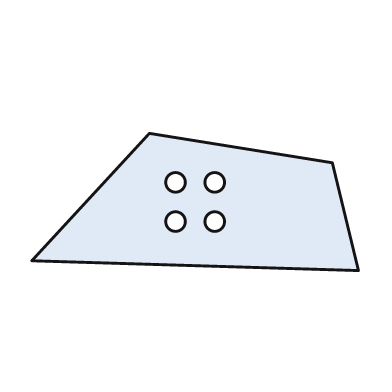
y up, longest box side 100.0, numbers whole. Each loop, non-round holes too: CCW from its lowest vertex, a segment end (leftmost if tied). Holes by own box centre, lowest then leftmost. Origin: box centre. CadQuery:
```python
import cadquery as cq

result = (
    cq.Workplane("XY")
    .moveTo(50.0, -21.0)
    .lineTo(42.0, 12.0)
    .lineTo(-14.0, 21.0)
    .lineTo(-50.0, -18.0)
    .close()
    .moveTo(-6.0, -6.0)
    .circle(3.0)
    .moveTo(6.0, -6.0)
    .circle(3.0)
    .moveTo(-6.0, 6.0)
    .circle(3.0)
    .moveTo(6.0, 6.0)
    .circle(3.0)
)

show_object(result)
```